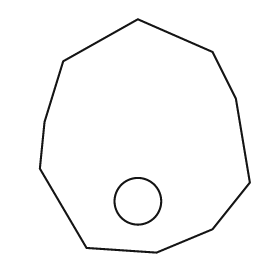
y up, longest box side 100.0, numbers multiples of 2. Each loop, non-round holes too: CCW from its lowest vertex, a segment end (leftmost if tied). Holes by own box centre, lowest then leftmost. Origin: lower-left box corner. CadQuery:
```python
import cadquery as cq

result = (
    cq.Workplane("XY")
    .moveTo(50.0, 0.0)
    .lineTo(74.0, 10.0)
    .lineTo(90.0, 30.0)
    .lineTo(84.0, 66.0)
    .lineTo(74.0, 86.0)
    .lineTo(42.0, 100.0)
    .lineTo(10.0, 82.0)
    .lineTo(2.0, 56.0)
    .lineTo(0.0, 36.0)
    .lineTo(20.0, 2.0)
    .close()
    .moveTo(42.0, 22.0)
    .circle(10.0)
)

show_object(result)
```